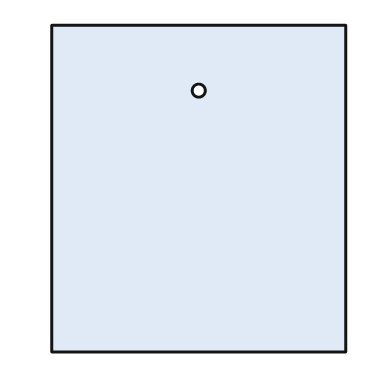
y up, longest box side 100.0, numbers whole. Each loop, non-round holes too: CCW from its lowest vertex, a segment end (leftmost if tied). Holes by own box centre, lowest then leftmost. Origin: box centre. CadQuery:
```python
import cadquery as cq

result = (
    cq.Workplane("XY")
    .moveTo(-45.0, -50.0)
    .lineTo(45.0, -50.0)
    .lineTo(45.0, 50.0)
    .lineTo(-45.0, 50.0)
    .close()
    .moveTo(0.0, 30.0)
    .circle(2.0)
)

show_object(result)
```